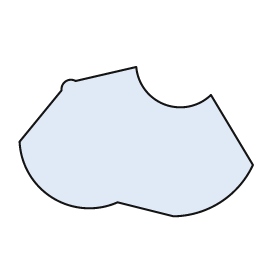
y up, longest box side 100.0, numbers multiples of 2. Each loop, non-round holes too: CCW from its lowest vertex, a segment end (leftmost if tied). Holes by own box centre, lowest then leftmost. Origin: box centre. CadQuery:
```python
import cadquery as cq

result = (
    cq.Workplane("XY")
    .moveTo(16.0, -32.0)
    .threePointArc((36.0, -26.0), (50.0, -10.0))
    .lineTo(32.0, 20.0)
    .threePointArc((12.0, 16.0), (0.0, 32.0))
    .lineTo(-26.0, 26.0)
    .threePointArc((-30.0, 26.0), (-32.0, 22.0))
    .lineTo(-50.0, 0.0)
    .threePointArc((-36.0, -24.0), (-8.0, -26.0))
    .close()
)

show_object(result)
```